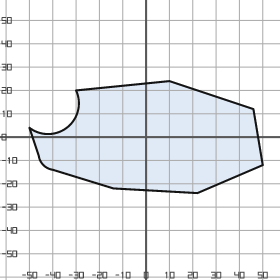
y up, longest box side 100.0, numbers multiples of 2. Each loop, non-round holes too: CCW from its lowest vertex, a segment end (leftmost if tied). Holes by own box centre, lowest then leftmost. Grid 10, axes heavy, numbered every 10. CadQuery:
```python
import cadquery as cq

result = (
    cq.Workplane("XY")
    .moveTo(22.0, -24.0)
    .lineTo(50.0, -12.0)
    .lineTo(46.0, 12.0)
    .lineTo(10.0, 24.0)
    .lineTo(-30.0, 20.0)
    .threePointArc((-34.0, 4.0), (-50.0, 4.0))
    .lineTo(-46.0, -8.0)
    .threePointArc((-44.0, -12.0), (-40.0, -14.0))
    .lineTo(-14.0, -22.0)
    .close()
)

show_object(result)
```